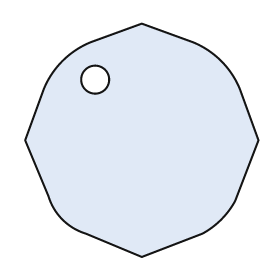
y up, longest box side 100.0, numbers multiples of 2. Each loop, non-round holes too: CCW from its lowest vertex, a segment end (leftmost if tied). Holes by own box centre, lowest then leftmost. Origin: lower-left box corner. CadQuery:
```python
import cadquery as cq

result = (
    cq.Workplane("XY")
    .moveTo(50.0, 0.0)
    .lineTo(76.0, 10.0)
    .threePointArc((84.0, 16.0), (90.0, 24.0))
    .lineTo(100.0, 50.0)
    .lineTo(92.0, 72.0)
    .threePointArc((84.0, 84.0), (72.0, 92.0))
    .lineTo(50.0, 100.0)
    .lineTo(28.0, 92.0)
    .threePointArc((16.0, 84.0), (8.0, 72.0))
    .lineTo(0.0, 50.0)
    .lineTo(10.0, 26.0)
    .threePointArc((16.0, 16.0), (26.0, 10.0))
    .close()
    .moveTo(30.0, 76.0)
    .circle(6.0)
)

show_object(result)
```